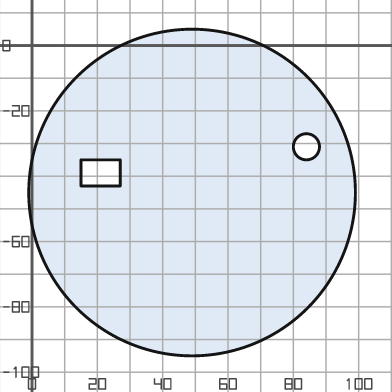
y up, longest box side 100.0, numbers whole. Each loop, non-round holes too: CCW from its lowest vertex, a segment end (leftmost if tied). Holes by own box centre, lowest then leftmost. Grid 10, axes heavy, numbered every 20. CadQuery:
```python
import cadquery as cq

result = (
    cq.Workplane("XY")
    .moveTo(49.0, -45.0)
    .circle(50.0)
    .moveTo(15.0, -43.0)
    .lineTo(27.0, -43.0)
    .lineTo(27.0, -35.0)
    .lineTo(15.0, -35.0)
    .close()
    .moveTo(84.0, -31.0)
    .circle(4.0)
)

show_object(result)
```